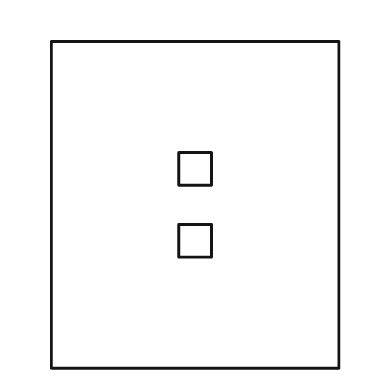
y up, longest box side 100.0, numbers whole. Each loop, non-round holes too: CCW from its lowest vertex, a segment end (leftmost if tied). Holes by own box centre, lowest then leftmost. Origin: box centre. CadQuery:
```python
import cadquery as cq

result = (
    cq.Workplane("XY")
    .moveTo(-44.0, -50.0)
    .lineTo(44.0, -50.0)
    .lineTo(44.0, 50.0)
    .lineTo(-44.0, 50.0)
    .close()
    .moveTo(-5.0, -16.0)
    .lineTo(5.0, -16.0)
    .lineTo(5.0, -6.0)
    .lineTo(-5.0, -6.0)
    .close()
    .moveTo(-5.0, 6.0)
    .lineTo(5.0, 6.0)
    .lineTo(5.0, 16.0)
    .lineTo(-5.0, 16.0)
    .close()
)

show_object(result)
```